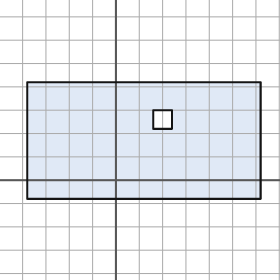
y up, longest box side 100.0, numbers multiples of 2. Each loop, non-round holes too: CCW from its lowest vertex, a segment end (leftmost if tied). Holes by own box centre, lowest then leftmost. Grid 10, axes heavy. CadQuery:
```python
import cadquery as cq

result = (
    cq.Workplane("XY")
    .moveTo(-38.0, -8.0)
    .lineTo(62.0, -8.0)
    .lineTo(62.0, 42.0)
    .lineTo(-38.0, 42.0)
    .close()
    .moveTo(16.0, 22.0)
    .lineTo(24.0, 22.0)
    .lineTo(24.0, 30.0)
    .lineTo(16.0, 30.0)
    .close()
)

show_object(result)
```